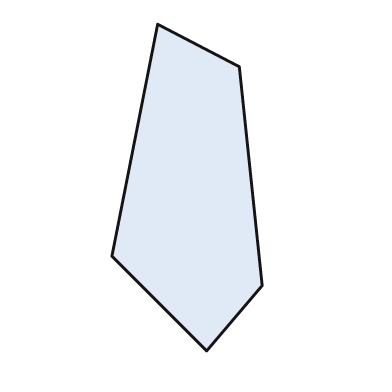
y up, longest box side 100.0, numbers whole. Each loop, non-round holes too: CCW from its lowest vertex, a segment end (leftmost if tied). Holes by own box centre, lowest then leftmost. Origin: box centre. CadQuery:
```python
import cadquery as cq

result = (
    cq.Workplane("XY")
    .moveTo(6.0, -50.0)
    .lineTo(23.0, -30.0)
    .lineTo(16.0, 37.0)
    .lineTo(-9.0, 50.0)
    .lineTo(-23.0, -21.0)
    .close()
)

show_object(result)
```